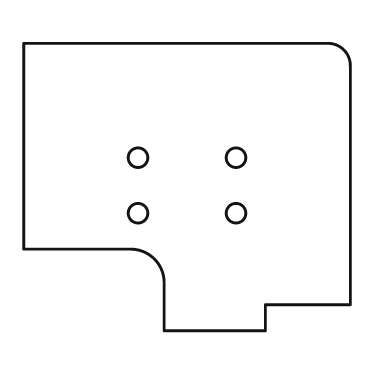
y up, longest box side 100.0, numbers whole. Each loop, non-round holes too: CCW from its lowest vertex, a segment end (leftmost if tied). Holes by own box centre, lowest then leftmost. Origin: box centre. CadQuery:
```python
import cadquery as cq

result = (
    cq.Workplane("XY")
    .moveTo(-7.0, -44.0)
    .lineTo(24.0, -44.0)
    .lineTo(24.0, -36.0)
    .lineTo(50.0, -36.0)
    .lineTo(50.0, 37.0)
    .threePointArc((48.0, 42.0), (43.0, 44.0))
    .lineTo(-50.0, 44.0)
    .lineTo(-50.0, -19.0)
    .lineTo(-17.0, -19.0)
    .threePointArc((-10.0, -22.0), (-7.0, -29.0))
    .close()
    .moveTo(-15.0, -8.0)
    .circle(3.0)
    .moveTo(15.0, -8.0)
    .circle(3.0)
    .moveTo(-15.0, 9.0)
    .circle(3.0)
    .moveTo(15.0, 9.0)
    .circle(3.0)
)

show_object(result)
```